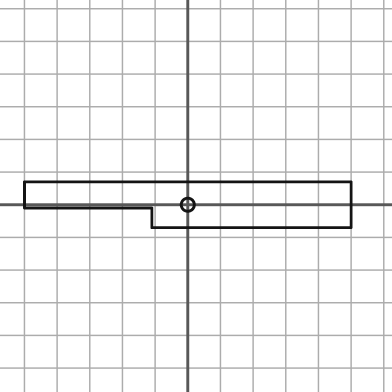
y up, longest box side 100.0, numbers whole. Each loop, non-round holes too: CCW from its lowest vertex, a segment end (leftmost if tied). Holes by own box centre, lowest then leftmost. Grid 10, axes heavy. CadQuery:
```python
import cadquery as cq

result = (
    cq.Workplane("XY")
    .moveTo(-11.0, -7.0)
    .lineTo(50.0, -7.0)
    .lineTo(50.0, 7.0)
    .lineTo(-50.0, 7.0)
    .lineTo(-50.0, -1.0)
    .lineTo(-11.0, -1.0)
    .close()
    .moveTo(0.0, 0.0)
    .circle(2.0)
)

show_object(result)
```